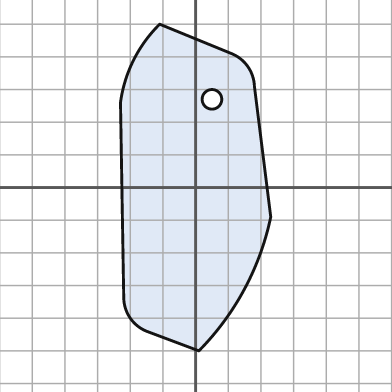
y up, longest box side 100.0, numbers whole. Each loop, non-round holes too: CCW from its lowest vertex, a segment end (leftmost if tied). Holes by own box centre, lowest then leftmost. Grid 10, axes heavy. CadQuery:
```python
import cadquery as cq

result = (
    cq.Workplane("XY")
    .moveTo(1.0, -50.0)
    .threePointArc((15.0, -31.0), (23.0, -9.0))
    .lineTo(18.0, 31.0)
    .threePointArc((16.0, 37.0), (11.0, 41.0))
    .lineTo(-11.0, 50.0)
    .threePointArc((-19.0, 39.0), (-23.0, 26.0))
    .lineTo(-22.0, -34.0)
    .threePointArc((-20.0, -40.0), (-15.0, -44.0))
    .close()
    .moveTo(5.0, 27.0)
    .circle(3.0)
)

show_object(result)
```